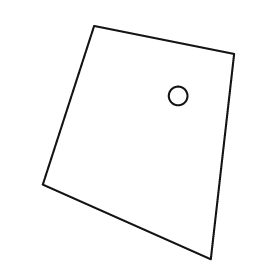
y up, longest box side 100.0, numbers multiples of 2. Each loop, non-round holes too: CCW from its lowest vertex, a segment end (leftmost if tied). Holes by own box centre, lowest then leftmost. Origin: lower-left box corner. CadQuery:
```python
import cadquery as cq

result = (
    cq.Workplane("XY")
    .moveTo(72.0, 0.0)
    .lineTo(82.0, 88.0)
    .lineTo(22.0, 100.0)
    .lineTo(0.0, 32.0)
    .close()
    .moveTo(58.0, 70.0)
    .circle(4.0)
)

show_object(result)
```